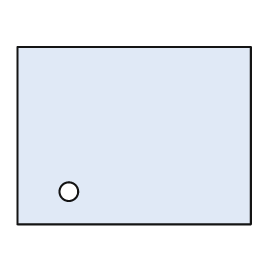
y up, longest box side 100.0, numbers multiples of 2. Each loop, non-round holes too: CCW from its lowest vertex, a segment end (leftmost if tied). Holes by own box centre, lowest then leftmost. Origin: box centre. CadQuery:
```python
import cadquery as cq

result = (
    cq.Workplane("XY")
    .moveTo(-50.0, -38.0)
    .lineTo(50.0, -38.0)
    .lineTo(50.0, 38.0)
    .lineTo(-50.0, 38.0)
    .close()
    .moveTo(-28.0, -24.0)
    .circle(4.0)
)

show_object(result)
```